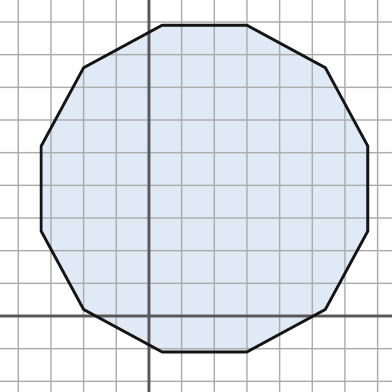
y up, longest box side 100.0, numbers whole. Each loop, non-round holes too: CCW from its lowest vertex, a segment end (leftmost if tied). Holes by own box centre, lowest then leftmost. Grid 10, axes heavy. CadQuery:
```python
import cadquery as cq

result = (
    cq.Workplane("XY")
    .moveTo(4.0, -11.0)
    .lineTo(30.0, -11.0)
    .lineTo(54.0, 2.0)
    .lineTo(67.0, 26.0)
    .lineTo(67.0, 52.0)
    .lineTo(54.0, 76.0)
    .lineTo(30.0, 89.0)
    .lineTo(4.0, 89.0)
    .lineTo(-20.0, 76.0)
    .lineTo(-33.0, 52.0)
    .lineTo(-33.0, 26.0)
    .lineTo(-20.0, 2.0)
    .close()
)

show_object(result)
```